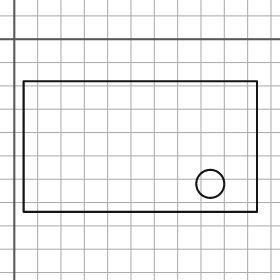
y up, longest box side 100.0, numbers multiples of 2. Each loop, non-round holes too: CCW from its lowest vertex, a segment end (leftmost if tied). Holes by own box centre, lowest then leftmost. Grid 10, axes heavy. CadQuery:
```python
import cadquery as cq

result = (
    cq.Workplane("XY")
    .moveTo(4.0, -74.0)
    .lineTo(104.0, -74.0)
    .lineTo(104.0, -18.0)
    .lineTo(4.0, -18.0)
    .close()
    .moveTo(84.0, -62.0)
    .circle(6.0)
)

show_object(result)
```